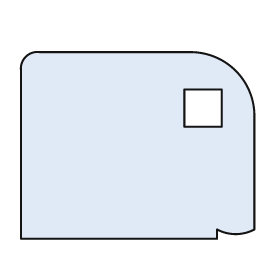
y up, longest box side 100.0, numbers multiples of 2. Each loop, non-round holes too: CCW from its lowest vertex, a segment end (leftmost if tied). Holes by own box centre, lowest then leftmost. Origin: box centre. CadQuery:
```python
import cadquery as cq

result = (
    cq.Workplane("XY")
    .moveTo(-50.0, -40.0)
    .lineTo(34.0, -40.0)
    .lineTo(34.0, -36.0)
    .threePointArc((42.0, -38.0), (50.0, -36.0))
    .lineTo(50.0, 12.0)
    .threePointArc((42.0, 32.0), (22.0, 40.0))
    .lineTo(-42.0, 40.0)
    .threePointArc((-48.0, 38.0), (-50.0, 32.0))
    .close()
    .moveTo(20.0, 8.0)
    .lineTo(36.0, 8.0)
    .lineTo(36.0, 24.0)
    .lineTo(20.0, 24.0)
    .close()
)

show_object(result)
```